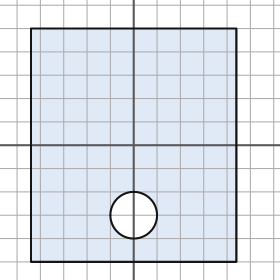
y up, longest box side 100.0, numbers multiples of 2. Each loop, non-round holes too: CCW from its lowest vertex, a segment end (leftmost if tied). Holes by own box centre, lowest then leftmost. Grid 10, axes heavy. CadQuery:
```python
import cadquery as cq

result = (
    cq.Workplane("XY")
    .moveTo(-44.0, -50.0)
    .lineTo(44.0, -50.0)
    .lineTo(44.0, 50.0)
    .lineTo(-44.0, 50.0)
    .close()
    .moveTo(0.0, -30.0)
    .circle(10.0)
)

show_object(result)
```